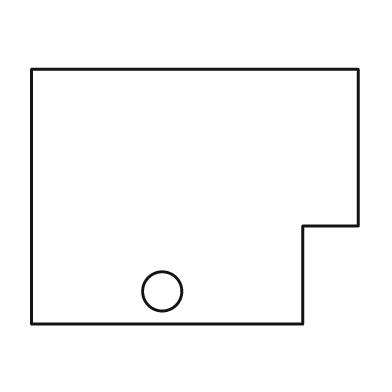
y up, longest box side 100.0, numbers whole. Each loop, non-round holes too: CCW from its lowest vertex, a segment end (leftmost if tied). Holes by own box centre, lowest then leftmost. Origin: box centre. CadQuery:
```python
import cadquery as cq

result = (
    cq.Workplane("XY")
    .moveTo(-50.0, -39.0)
    .lineTo(33.0, -39.0)
    .lineTo(33.0, -9.0)
    .lineTo(50.0, -9.0)
    .lineTo(50.0, 39.0)
    .lineTo(-50.0, 39.0)
    .close()
    .moveTo(-10.0, -29.0)
    .circle(6.0)
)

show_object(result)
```